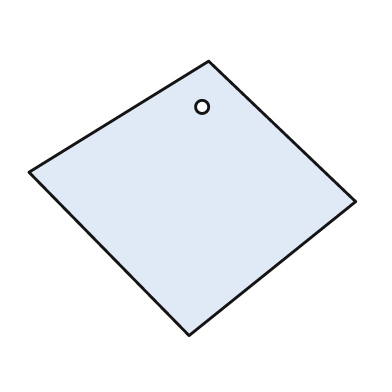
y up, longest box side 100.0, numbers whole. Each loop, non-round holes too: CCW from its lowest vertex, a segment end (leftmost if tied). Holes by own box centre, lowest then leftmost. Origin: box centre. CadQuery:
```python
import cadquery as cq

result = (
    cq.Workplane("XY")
    .moveTo(-1.0, -42.0)
    .lineTo(50.0, -1.0)
    .lineTo(5.0, 42.0)
    .lineTo(-50.0, 8.0)
    .close()
    .moveTo(3.0, 28.0)
    .circle(2.0)
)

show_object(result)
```